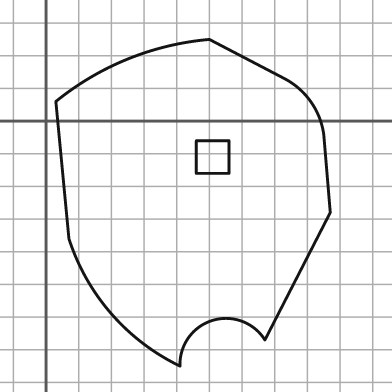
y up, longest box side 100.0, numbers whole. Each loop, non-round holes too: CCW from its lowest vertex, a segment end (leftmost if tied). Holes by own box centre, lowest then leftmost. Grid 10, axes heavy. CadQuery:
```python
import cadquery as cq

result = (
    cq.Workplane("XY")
    .moveTo(41.0, -75.0)
    .threePointArc((51.0, -61.0), (67.0, -67.0))
    .lineTo(87.0, -28.0)
    .lineTo(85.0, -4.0)
    .threePointArc((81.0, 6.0), (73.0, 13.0))
    .lineTo(50.0, 25.0)
    .threePointArc((25.0, 19.0), (3.0, 6.0))
    .lineTo(7.0, -36.0)
    .threePointArc((20.0, -59.0), (41.0, -75.0))
    .close()
    .moveTo(46.0, -16.0)
    .lineTo(56.0, -16.0)
    .lineTo(56.0, -6.0)
    .lineTo(46.0, -6.0)
    .close()
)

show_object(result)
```